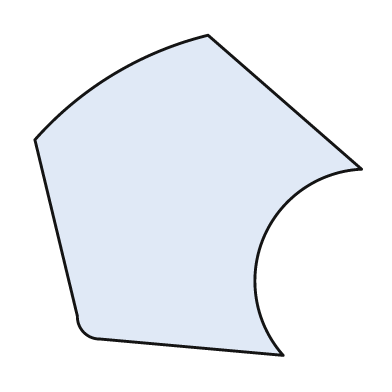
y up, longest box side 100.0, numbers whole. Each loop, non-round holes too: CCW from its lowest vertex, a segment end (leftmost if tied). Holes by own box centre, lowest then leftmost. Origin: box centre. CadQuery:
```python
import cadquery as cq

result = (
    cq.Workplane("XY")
    .moveTo(26.0, -49.0)
    .threePointArc((20.0, -13.0), (50.0, 8.0))
    .lineTo(3.0, 49.0)
    .threePointArc((-26.0, 37.0), (-50.0, 17.0))
    .lineTo(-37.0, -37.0)
    .threePointArc((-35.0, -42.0), (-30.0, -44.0))
    .close()
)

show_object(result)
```